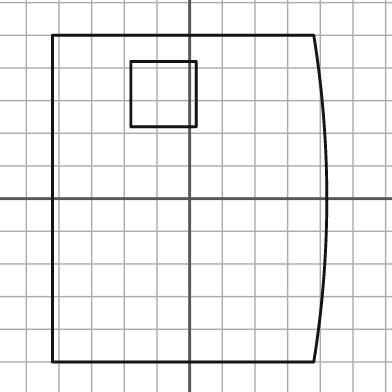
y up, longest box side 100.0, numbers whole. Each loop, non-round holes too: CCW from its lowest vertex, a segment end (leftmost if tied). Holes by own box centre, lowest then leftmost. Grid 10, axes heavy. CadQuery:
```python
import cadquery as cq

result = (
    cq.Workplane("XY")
    .moveTo(-42.0, -50.0)
    .lineTo(38.0, -50.0)
    .threePointArc((42.0, 0.0), (38.0, 50.0))
    .lineTo(-42.0, 50.0)
    .close()
    .moveTo(-18.0, 22.0)
    .lineTo(2.0, 22.0)
    .lineTo(2.0, 42.0)
    .lineTo(-18.0, 42.0)
    .close()
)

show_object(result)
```